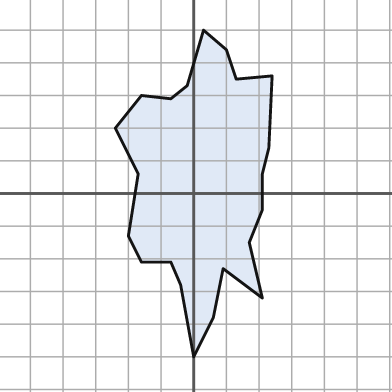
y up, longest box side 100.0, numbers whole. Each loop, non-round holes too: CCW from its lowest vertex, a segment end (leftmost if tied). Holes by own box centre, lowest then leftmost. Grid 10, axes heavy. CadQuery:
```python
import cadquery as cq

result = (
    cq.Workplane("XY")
    .moveTo(0.0, -50.0)
    .lineTo(6.0, -38.0)
    .lineTo(9.0, -23.0)
    .lineTo(21.0, -32.0)
    .lineTo(17.0, -15.0)
    .lineTo(21.0, -5.0)
    .lineTo(21.0, 6.0)
    .lineTo(23.0, 14.0)
    .lineTo(24.0, 36.0)
    .lineTo(13.0, 35.0)
    .lineTo(10.0, 44.0)
    .lineTo(3.0, 50.0)
    .lineTo(-2.0, 33.0)
    .lineTo(-7.0, 29.0)
    .lineTo(-16.0, 30.0)
    .lineTo(-24.0, 20.0)
    .lineTo(-17.0, 6.0)
    .lineTo(-20.0, -13.0)
    .lineTo(-16.0, -21.0)
    .lineTo(-7.0, -21.0)
    .lineTo(-4.0, -28.0)
    .close()
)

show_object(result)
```